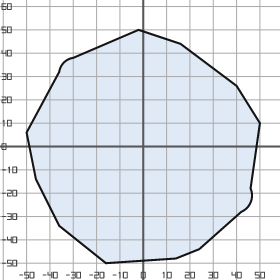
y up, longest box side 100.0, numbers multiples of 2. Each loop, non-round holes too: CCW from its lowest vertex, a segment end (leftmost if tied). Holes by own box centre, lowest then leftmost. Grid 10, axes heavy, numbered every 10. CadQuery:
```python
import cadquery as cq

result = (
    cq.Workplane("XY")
    .moveTo(-16.0, -50.0)
    .lineTo(14.0, -48.0)
    .lineTo(24.0, -44.0)
    .lineTo(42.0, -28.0)
    .threePointArc((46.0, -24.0), (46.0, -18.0))
    .lineTo(50.0, 10.0)
    .lineTo(40.0, 26.0)
    .lineTo(16.0, 44.0)
    .lineTo(-2.0, 50.0)
    .lineTo(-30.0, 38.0)
    .threePointArc((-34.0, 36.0), (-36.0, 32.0))
    .lineTo(-50.0, 6.0)
    .lineTo(-46.0, -14.0)
    .lineTo(-36.0, -34.0)
    .close()
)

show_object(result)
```